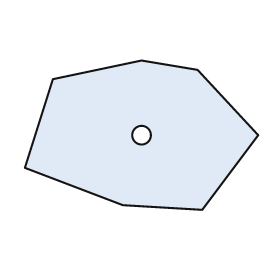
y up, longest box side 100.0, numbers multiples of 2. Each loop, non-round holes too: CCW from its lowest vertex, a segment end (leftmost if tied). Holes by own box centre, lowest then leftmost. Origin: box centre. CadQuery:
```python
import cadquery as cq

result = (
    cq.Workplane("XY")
    .moveTo(26.0, -32.0)
    .lineTo(50.0, 0.0)
    .lineTo(24.0, 28.0)
    .lineTo(0.0, 32.0)
    .lineTo(-38.0, 24.0)
    .lineTo(-50.0, -14.0)
    .lineTo(-8.0, -30.0)
    .close()
    .moveTo(0.0, 0.0)
    .circle(4.0)
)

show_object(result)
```